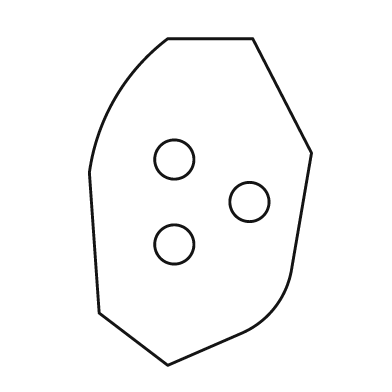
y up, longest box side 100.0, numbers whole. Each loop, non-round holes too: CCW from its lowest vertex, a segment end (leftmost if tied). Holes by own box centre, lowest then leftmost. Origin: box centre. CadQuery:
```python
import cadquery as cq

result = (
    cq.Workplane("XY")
    .moveTo(-10.0, -50.0)
    .lineTo(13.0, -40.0)
    .threePointArc((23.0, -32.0), (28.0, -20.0))
    .lineTo(34.0, 15.0)
    .lineTo(16.0, 50.0)
    .lineTo(-10.0, 50.0)
    .threePointArc((-26.0, 32.0), (-34.0, 9.0))
    .lineTo(-31.0, -34.0)
    .close()
    .moveTo(-8.0, -13.0)
    .circle(6.0)
    .moveTo(15.0, 0.0)
    .circle(6.0)
    .moveTo(-8.0, 13.0)
    .circle(6.0)
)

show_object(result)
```